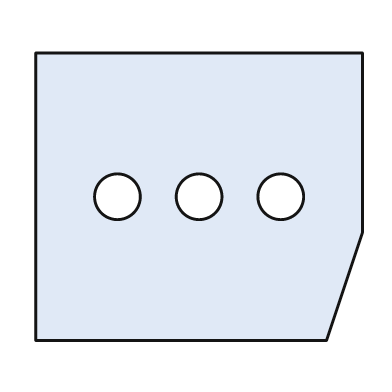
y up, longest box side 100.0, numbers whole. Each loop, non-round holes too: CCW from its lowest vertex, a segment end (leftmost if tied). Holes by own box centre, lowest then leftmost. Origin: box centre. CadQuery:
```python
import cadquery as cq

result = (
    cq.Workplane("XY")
    .moveTo(-50.0, -44.0)
    .lineTo(39.0, -44.0)
    .lineTo(50.0, -11.0)
    .lineTo(50.0, 44.0)
    .lineTo(-50.0, 44.0)
    .close()
    .moveTo(-25.0, 0.0)
    .circle(7.0)
    .moveTo(0.0, 0.0)
    .circle(7.0)
    .moveTo(25.0, 0.0)
    .circle(7.0)
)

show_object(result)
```